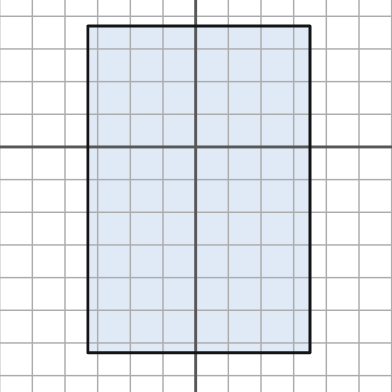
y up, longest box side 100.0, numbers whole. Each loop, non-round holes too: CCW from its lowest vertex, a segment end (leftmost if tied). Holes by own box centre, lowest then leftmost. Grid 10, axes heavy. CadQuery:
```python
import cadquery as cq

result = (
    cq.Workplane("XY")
    .moveTo(-33.0, -63.0)
    .lineTo(35.0, -63.0)
    .lineTo(35.0, 37.0)
    .lineTo(-33.0, 37.0)
    .close()
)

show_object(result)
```